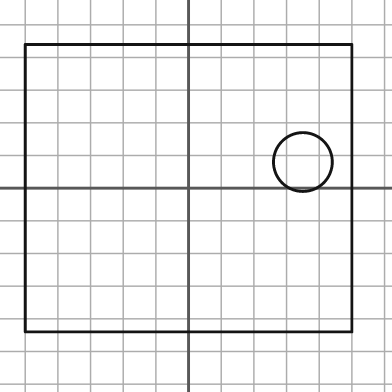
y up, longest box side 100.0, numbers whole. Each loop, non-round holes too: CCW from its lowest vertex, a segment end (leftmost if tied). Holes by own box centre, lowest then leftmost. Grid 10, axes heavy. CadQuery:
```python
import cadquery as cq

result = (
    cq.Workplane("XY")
    .moveTo(-50.0, -44.0)
    .lineTo(50.0, -44.0)
    .lineTo(50.0, 44.0)
    .lineTo(-50.0, 44.0)
    .close()
    .moveTo(35.0, 8.0)
    .circle(9.0)
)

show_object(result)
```